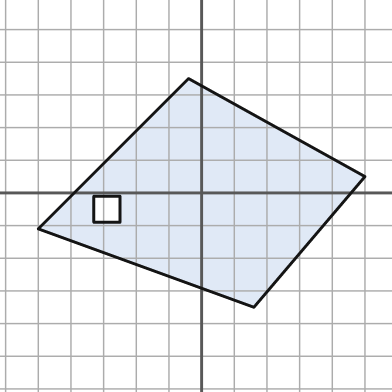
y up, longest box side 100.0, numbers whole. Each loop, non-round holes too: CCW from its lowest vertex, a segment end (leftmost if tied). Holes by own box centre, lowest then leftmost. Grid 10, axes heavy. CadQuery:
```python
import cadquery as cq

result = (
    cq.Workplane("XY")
    .moveTo(16.0, -35.0)
    .lineTo(50.0, 5.0)
    .lineTo(-4.0, 35.0)
    .lineTo(-50.0, -11.0)
    .close()
    .moveTo(-33.0, -9.0)
    .lineTo(-25.0, -9.0)
    .lineTo(-25.0, -1.0)
    .lineTo(-33.0, -1.0)
    .close()
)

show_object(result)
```